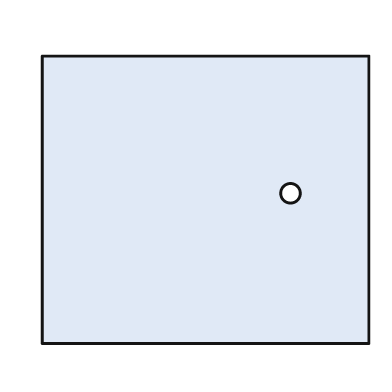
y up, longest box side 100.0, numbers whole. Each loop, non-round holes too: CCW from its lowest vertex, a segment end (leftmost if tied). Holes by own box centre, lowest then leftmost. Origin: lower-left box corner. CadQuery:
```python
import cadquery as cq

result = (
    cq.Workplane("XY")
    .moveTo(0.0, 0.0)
    .lineTo(100.0, 0.0)
    .lineTo(100.0, 88.0)
    .lineTo(0.0, 88.0)
    .close()
    .moveTo(76.0, 46.0)
    .circle(3.0)
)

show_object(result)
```